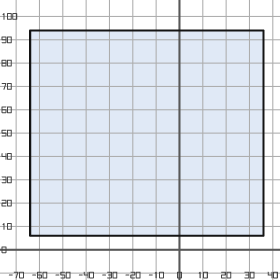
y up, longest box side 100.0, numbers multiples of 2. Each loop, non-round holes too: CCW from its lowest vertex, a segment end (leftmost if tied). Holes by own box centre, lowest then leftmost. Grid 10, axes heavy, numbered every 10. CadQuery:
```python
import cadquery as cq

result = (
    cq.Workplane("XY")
    .moveTo(-64.0, 6.0)
    .lineTo(36.0, 6.0)
    .lineTo(36.0, 94.0)
    .lineTo(-64.0, 94.0)
    .close()
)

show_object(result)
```